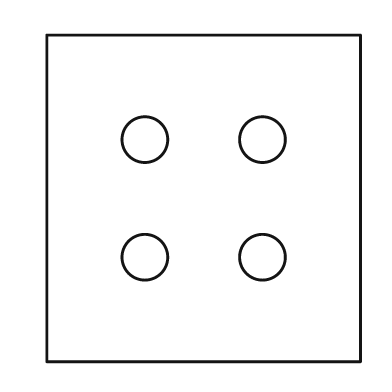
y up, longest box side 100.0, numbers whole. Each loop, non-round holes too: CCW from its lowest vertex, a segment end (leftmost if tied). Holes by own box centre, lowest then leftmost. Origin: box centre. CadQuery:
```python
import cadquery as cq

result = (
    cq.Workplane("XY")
    .moveTo(-48.0, -50.0)
    .lineTo(48.0, -50.0)
    .lineTo(48.0, 50.0)
    .lineTo(-48.0, 50.0)
    .close()
    .moveTo(-18.0, -18.0)
    .circle(7.0)
    .moveTo(18.0, -18.0)
    .circle(7.0)
    .moveTo(-18.0, 18.0)
    .circle(7.0)
    .moveTo(18.0, 18.0)
    .circle(7.0)
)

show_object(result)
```